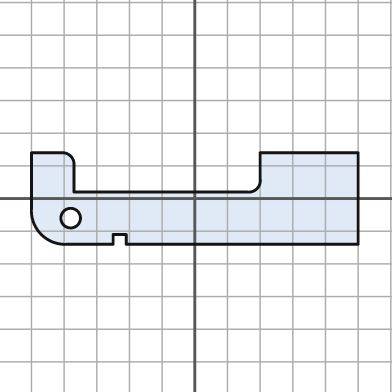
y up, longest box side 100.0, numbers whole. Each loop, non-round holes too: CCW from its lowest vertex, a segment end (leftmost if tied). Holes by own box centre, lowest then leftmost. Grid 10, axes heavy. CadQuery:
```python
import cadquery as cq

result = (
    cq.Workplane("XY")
    .moveTo(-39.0, -14.0)
    .lineTo(-25.0, -14.0)
    .lineTo(-25.0, -11.0)
    .lineTo(-21.0, -11.0)
    .lineTo(-21.0, -14.0)
    .lineTo(50.0, -14.0)
    .lineTo(50.0, 14.0)
    .lineTo(20.0, 14.0)
    .lineTo(20.0, 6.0)
    .threePointArc((19.0, 3.0), (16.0, 2.0))
    .lineTo(-37.0, 2.0)
    .lineTo(-37.0, 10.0)
    .threePointArc((-38.0, 13.0), (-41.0, 14.0))
    .lineTo(-50.0, 14.0)
    .lineTo(-50.0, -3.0)
    .threePointArc((-47.0, -11.0), (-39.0, -14.0))
    .close()
    .moveTo(-38.0, -6.0)
    .circle(3.0)
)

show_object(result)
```